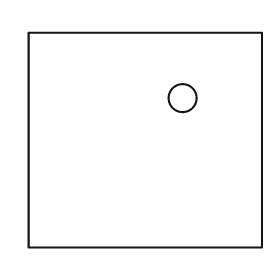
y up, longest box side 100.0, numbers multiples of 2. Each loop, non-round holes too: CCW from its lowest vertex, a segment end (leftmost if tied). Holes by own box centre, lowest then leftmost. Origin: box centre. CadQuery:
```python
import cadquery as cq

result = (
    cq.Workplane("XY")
    .moveTo(-50.0, -46.0)
    .lineTo(50.0, -46.0)
    .lineTo(50.0, 46.0)
    .lineTo(-50.0, 46.0)
    .close()
    .moveTo(16.0, 18.0)
    .circle(6.0)
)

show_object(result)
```